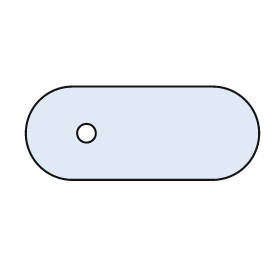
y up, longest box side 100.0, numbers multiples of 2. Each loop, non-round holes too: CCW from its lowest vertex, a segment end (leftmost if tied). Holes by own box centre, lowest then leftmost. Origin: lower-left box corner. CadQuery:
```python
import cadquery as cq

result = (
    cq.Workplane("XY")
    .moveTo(20.0, 0.0)
    .lineTo(80.0, 0.0)
    .threePointArc((100.0, 20.0), (80.0, 40.0))
    .lineTo(20.0, 40.0)
    .threePointArc((0.0, 20.0), (20.0, 0.0))
    .close()
    .moveTo(26.0, 20.0)
    .circle(4.0)
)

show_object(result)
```